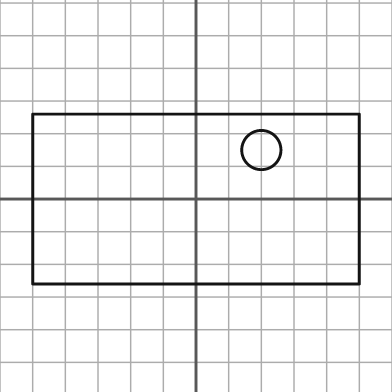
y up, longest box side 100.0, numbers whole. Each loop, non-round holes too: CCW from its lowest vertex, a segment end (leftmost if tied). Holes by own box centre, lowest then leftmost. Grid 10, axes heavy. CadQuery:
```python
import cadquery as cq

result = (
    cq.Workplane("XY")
    .moveTo(-50.0, -26.0)
    .lineTo(50.0, -26.0)
    .lineTo(50.0, 26.0)
    .lineTo(-50.0, 26.0)
    .close()
    .moveTo(20.0, 15.0)
    .circle(6.0)
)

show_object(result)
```